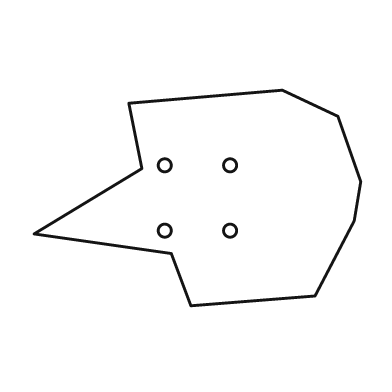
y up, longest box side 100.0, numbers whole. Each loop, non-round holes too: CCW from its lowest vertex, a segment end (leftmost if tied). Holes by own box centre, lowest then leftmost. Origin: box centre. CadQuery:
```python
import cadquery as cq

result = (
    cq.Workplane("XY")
    .moveTo(-2.0, -33.0)
    .lineTo(36.0, -30.0)
    .lineTo(48.0, -7.0)
    .lineTo(50.0, 5.0)
    .lineTo(43.0, 25.0)
    .lineTo(26.0, 33.0)
    .lineTo(-21.0, 29.0)
    .lineTo(-17.0, 9.0)
    .lineTo(-50.0, -11.0)
    .lineTo(-8.0, -17.0)
    .close()
    .moveTo(-10.0, -10.0)
    .circle(2.0)
    .moveTo(10.0, -10.0)
    .circle(2.0)
    .moveTo(-10.0, 10.0)
    .circle(2.0)
    .moveTo(10.0, 10.0)
    .circle(2.0)
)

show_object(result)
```